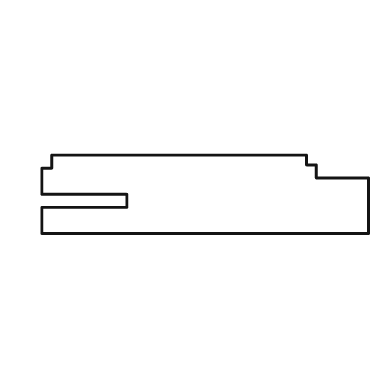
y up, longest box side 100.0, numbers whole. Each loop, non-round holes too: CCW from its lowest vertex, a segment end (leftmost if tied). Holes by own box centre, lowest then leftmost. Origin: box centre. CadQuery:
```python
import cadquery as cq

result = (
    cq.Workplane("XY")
    .moveTo(-50.0, -12.0)
    .lineTo(50.0, -12.0)
    .lineTo(50.0, 5.0)
    .lineTo(34.0, 5.0)
    .lineTo(34.0, 9.0)
    .lineTo(31.0, 9.0)
    .lineTo(31.0, 12.0)
    .lineTo(-47.0, 12.0)
    .lineTo(-47.0, 8.0)
    .lineTo(-50.0, 8.0)
    .lineTo(-50.0, 0.0)
    .lineTo(-24.0, 0.0)
    .lineTo(-24.0, -4.0)
    .lineTo(-50.0, -4.0)
    .close()
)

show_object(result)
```